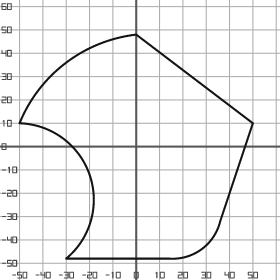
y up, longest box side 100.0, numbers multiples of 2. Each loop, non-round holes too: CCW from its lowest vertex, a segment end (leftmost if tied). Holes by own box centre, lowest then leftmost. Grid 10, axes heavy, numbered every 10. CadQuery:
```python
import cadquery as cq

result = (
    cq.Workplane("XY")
    .moveTo(-30.0, -48.0)
    .lineTo(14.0, -48.0)
    .threePointArc((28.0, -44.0), (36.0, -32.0))
    .lineTo(50.0, 10.0)
    .lineTo(0.0, 48.0)
    .threePointArc((-30.0, 36.0), (-50.0, 10.0))
    .threePointArc((-20.0, -12.0), (-30.0, -48.0))
    .close()
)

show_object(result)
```